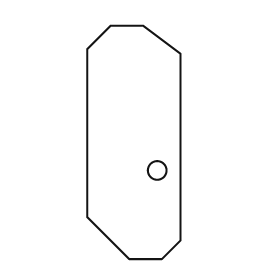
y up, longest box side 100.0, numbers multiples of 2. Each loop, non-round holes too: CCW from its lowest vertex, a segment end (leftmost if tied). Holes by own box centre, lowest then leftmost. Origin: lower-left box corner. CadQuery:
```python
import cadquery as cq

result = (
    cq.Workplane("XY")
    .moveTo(18.0, 0.0)
    .lineTo(32.0, 0.0)
    .lineTo(40.0, 8.0)
    .lineTo(40.0, 88.0)
    .lineTo(24.0, 100.0)
    .lineTo(10.0, 100.0)
    .lineTo(0.0, 90.0)
    .lineTo(0.0, 18.0)
    .close()
    .moveTo(30.0, 38.0)
    .circle(4.0)
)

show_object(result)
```